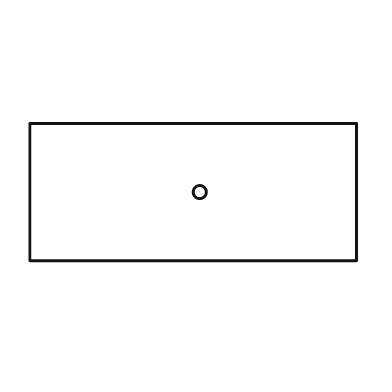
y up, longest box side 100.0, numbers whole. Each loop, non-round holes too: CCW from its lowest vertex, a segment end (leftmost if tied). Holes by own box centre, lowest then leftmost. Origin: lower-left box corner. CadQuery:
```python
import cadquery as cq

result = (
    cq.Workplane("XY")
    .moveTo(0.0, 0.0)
    .lineTo(100.0, 0.0)
    .lineTo(100.0, 42.0)
    .lineTo(0.0, 42.0)
    .close()
    .moveTo(52.0, 21.0)
    .circle(2.0)
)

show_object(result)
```